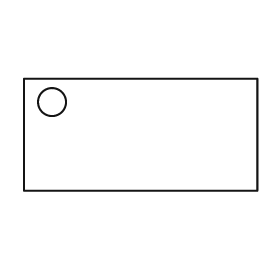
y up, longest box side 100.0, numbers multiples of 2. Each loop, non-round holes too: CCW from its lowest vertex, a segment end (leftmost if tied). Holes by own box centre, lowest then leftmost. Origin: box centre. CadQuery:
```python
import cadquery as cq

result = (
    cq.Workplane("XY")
    .moveTo(-50.0, -24.0)
    .lineTo(50.0, -24.0)
    .lineTo(50.0, 24.0)
    .lineTo(-50.0, 24.0)
    .close()
    .moveTo(-38.0, 14.0)
    .circle(6.0)
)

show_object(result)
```